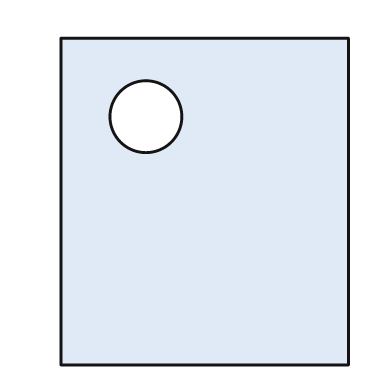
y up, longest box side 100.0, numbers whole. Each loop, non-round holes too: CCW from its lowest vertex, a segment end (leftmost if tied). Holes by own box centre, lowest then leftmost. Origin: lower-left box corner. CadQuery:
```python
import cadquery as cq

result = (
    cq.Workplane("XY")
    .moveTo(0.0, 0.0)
    .lineTo(88.0, 0.0)
    .lineTo(88.0, 100.0)
    .lineTo(0.0, 100.0)
    .close()
    .moveTo(26.0, 76.0)
    .circle(11.0)
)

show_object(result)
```